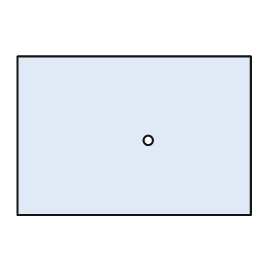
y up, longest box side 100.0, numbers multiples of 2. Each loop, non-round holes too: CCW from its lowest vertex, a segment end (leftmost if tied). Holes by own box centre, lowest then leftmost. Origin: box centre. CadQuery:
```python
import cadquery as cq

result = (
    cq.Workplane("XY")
    .moveTo(-50.0, -34.0)
    .lineTo(50.0, -34.0)
    .lineTo(50.0, 34.0)
    .lineTo(-50.0, 34.0)
    .close()
    .moveTo(6.0, -2.0)
    .circle(2.0)
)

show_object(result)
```